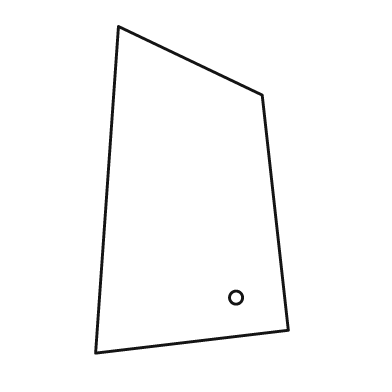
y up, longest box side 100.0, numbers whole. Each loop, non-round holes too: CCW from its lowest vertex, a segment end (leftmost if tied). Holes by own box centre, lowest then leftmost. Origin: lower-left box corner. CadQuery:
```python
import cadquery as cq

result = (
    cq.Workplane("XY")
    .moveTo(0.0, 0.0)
    .lineTo(59.0, 7.0)
    .lineTo(51.0, 79.0)
    .lineTo(7.0, 100.0)
    .close()
    .moveTo(43.0, 17.0)
    .circle(2.0)
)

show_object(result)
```